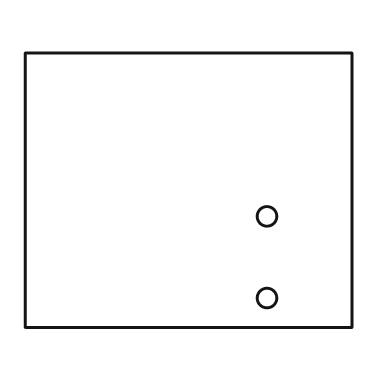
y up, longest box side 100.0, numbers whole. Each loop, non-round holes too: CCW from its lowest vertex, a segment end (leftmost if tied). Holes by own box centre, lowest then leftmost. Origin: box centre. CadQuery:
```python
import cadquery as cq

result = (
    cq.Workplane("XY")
    .moveTo(-50.0, -42.0)
    .lineTo(50.0, -42.0)
    .lineTo(50.0, 42.0)
    .lineTo(-50.0, 42.0)
    .close()
    .moveTo(24.0, -33.0)
    .circle(3.0)
    .moveTo(24.0, -8.0)
    .circle(3.0)
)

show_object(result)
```